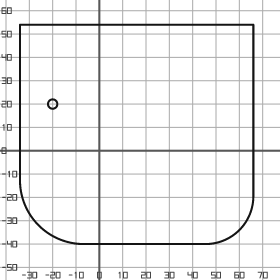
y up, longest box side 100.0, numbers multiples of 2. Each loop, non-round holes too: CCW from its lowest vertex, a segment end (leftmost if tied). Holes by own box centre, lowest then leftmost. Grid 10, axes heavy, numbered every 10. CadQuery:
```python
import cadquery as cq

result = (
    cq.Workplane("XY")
    .moveTo(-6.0, -40.0)
    .lineTo(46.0, -40.0)
    .threePointArc((60.0, -34.0), (66.0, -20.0))
    .lineTo(66.0, 54.0)
    .lineTo(-34.0, 54.0)
    .lineTo(-34.0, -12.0)
    .threePointArc((-26.0, -32.0), (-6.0, -40.0))
    .close()
    .moveTo(-20.0, 20.0)
    .circle(2.0)
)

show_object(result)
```